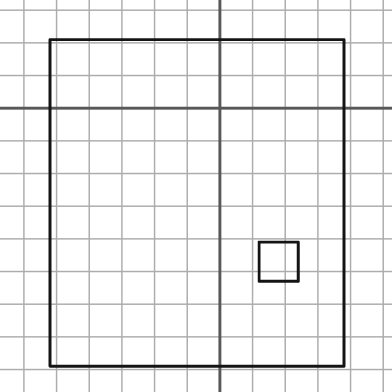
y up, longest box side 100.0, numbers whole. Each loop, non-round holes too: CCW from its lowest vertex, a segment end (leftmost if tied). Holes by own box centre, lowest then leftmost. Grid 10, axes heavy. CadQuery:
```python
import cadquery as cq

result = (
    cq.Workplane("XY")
    .moveTo(-52.0, -79.0)
    .lineTo(38.0, -79.0)
    .lineTo(38.0, 21.0)
    .lineTo(-52.0, 21.0)
    .close()
    .moveTo(12.0, -53.0)
    .lineTo(24.0, -53.0)
    .lineTo(24.0, -41.0)
    .lineTo(12.0, -41.0)
    .close()
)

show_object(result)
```